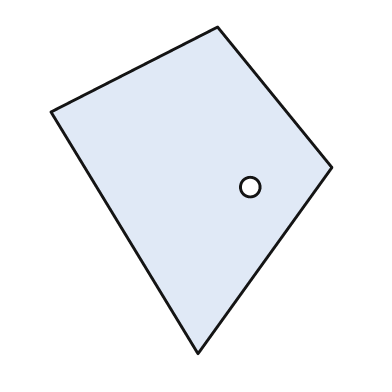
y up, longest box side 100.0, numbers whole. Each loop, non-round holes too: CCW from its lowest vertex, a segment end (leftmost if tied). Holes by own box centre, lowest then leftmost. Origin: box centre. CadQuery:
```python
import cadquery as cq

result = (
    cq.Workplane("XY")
    .moveTo(2.0, -50.0)
    .lineTo(43.0, 7.0)
    .lineTo(8.0, 50.0)
    .lineTo(-43.0, 24.0)
    .close()
    .moveTo(18.0, 1.0)
    .circle(3.0)
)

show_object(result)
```